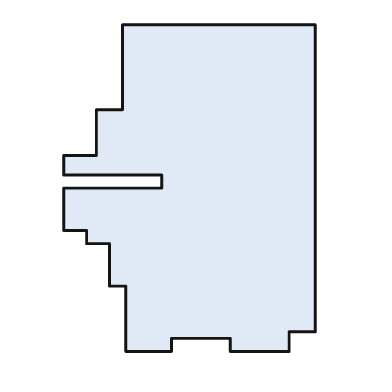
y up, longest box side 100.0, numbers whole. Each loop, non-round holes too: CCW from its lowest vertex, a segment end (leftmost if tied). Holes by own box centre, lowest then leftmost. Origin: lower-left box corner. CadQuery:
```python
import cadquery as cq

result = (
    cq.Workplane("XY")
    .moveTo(19.0, 0.0)
    .lineTo(33.0, 0.0)
    .lineTo(33.0, 4.0)
    .lineTo(51.0, 4.0)
    .lineTo(51.0, 0.0)
    .lineTo(69.0, 0.0)
    .lineTo(69.0, 6.0)
    .lineTo(77.0, 6.0)
    .lineTo(77.0, 100.0)
    .lineTo(18.0, 100.0)
    .lineTo(18.0, 74.0)
    .lineTo(10.0, 74.0)
    .lineTo(10.0, 60.0)
    .lineTo(0.0, 60.0)
    .lineTo(0.0, 54.0)
    .lineTo(30.0, 54.0)
    .lineTo(30.0, 50.0)
    .lineTo(0.0, 50.0)
    .lineTo(0.0, 37.0)
    .lineTo(7.0, 37.0)
    .lineTo(7.0, 33.0)
    .lineTo(14.0, 33.0)
    .lineTo(14.0, 20.0)
    .lineTo(19.0, 20.0)
    .close()
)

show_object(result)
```